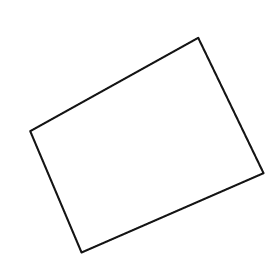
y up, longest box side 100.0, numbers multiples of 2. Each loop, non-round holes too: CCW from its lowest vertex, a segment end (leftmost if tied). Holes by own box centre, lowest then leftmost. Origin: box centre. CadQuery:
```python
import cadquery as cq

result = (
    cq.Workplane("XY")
    .moveTo(-28.0, -46.0)
    .lineTo(50.0, -12.0)
    .lineTo(22.0, 46.0)
    .lineTo(-50.0, 6.0)
    .close()
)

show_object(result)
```